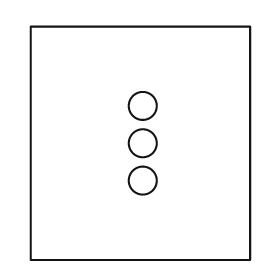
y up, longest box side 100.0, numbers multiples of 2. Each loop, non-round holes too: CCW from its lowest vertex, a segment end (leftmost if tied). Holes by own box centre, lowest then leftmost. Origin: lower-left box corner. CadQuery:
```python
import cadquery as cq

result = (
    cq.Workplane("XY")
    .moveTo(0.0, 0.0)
    .lineTo(94.0, 0.0)
    .lineTo(94.0, 100.0)
    .lineTo(0.0, 100.0)
    .close()
    .moveTo(48.0, 34.0)
    .circle(6.0)
    .moveTo(48.0, 50.0)
    .circle(6.0)
    .moveTo(48.0, 66.0)
    .circle(6.0)
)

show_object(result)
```